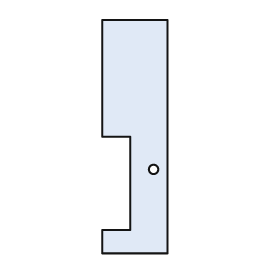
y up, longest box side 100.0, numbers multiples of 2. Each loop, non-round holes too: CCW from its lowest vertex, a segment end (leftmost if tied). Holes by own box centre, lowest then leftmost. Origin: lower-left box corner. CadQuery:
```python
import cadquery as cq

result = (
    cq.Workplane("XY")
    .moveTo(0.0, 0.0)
    .lineTo(28.0, 0.0)
    .lineTo(28.0, 100.0)
    .lineTo(0.0, 100.0)
    .lineTo(0.0, 50.0)
    .lineTo(12.0, 50.0)
    .lineTo(12.0, 10.0)
    .lineTo(0.0, 10.0)
    .close()
    .moveTo(22.0, 36.0)
    .circle(2.0)
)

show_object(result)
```